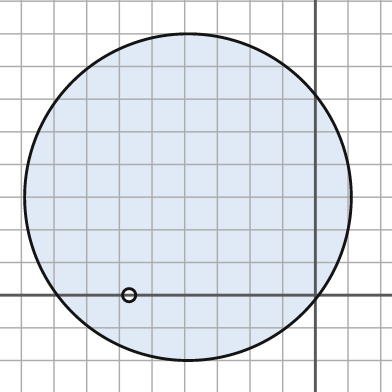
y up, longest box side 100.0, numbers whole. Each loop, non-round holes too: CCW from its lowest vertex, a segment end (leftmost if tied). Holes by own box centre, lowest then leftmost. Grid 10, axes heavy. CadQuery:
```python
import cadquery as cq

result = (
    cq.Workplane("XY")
    .moveTo(-39.0, 30.0)
    .circle(50.0)
    .moveTo(-57.0, 0.0)
    .circle(2.0)
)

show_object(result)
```